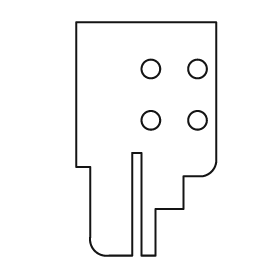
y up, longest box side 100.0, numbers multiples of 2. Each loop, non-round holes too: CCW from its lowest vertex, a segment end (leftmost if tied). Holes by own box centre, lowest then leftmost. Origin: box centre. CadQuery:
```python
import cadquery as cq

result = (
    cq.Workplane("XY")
    .moveTo(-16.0, -50.0)
    .lineTo(-6.0, -50.0)
    .lineTo(-6.0, -6.0)
    .lineTo(-2.0, -6.0)
    .lineTo(-2.0, -50.0)
    .lineTo(4.0, -50.0)
    .lineTo(4.0, -30.0)
    .lineTo(16.0, -30.0)
    .lineTo(16.0, -16.0)
    .lineTo(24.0, -16.0)
    .threePointArc((28.0, -14.0), (30.0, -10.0))
    .lineTo(30.0, 50.0)
    .lineTo(-30.0, 50.0)
    .lineTo(-30.0, -12.0)
    .lineTo(-24.0, -12.0)
    .lineTo(-24.0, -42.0)
    .threePointArc((-22.0, -48.0), (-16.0, -50.0))
    .close()
    .moveTo(2.0, 8.0)
    .circle(4.0)
    .moveTo(22.0, 8.0)
    .circle(4.0)
    .moveTo(2.0, 30.0)
    .circle(4.0)
    .moveTo(22.0, 30.0)
    .circle(4.0)
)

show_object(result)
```